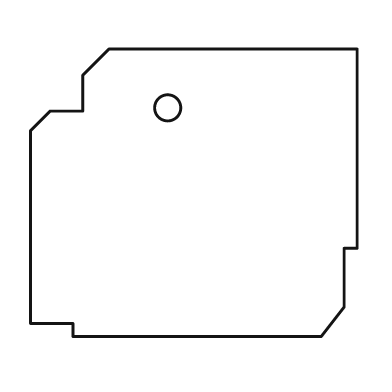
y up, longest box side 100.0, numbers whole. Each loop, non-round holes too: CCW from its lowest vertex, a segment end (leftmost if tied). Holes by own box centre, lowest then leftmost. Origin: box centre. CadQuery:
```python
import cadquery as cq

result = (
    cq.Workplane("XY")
    .moveTo(-37.0, -44.0)
    .lineTo(39.0, -44.0)
    .lineTo(46.0, -35.0)
    .lineTo(46.0, -17.0)
    .lineTo(50.0, -17.0)
    .lineTo(50.0, 44.0)
    .lineTo(-26.0, 44.0)
    .lineTo(-34.0, 36.0)
    .lineTo(-34.0, 25.0)
    .lineTo(-44.0, 25.0)
    .lineTo(-50.0, 19.0)
    .lineTo(-50.0, -40.0)
    .lineTo(-37.0, -40.0)
    .close()
    .moveTo(-8.0, 26.0)
    .circle(4.0)
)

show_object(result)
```